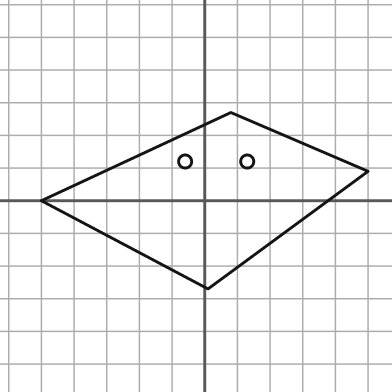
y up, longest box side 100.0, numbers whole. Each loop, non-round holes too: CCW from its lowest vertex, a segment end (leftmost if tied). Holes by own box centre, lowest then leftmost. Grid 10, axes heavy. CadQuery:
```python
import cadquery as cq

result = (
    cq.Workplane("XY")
    .moveTo(1.0, -27.0)
    .lineTo(50.0, 9.0)
    .lineTo(8.0, 27.0)
    .lineTo(-50.0, 0.0)
    .close()
    .moveTo(-6.0, 12.0)
    .circle(2.0)
    .moveTo(13.0, 12.0)
    .circle(2.0)
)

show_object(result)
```